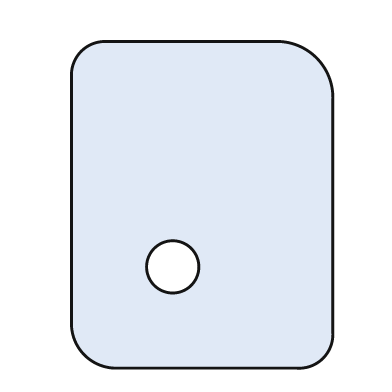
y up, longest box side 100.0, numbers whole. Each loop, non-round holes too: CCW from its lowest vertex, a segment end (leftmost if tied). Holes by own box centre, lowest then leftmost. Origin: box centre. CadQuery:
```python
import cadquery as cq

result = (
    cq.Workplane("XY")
    .moveTo(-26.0, -50.0)
    .lineTo(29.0, -50.0)
    .threePointArc((37.0, -47.0), (40.0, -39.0))
    .lineTo(40.0, 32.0)
    .threePointArc((35.0, 45.0), (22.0, 50.0))
    .lineTo(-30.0, 50.0)
    .threePointArc((-37.0, 47.0), (-40.0, 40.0))
    .lineTo(-40.0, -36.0)
    .threePointArc((-36.0, -46.0), (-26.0, -50.0))
    .close()
    .moveTo(-9.0, -19.0)
    .circle(8.0)
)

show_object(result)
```